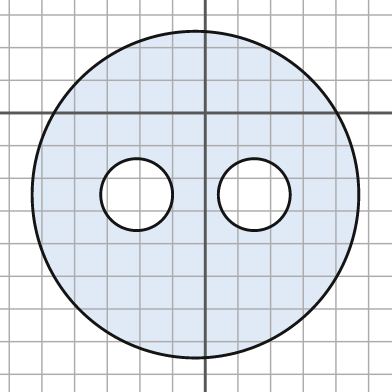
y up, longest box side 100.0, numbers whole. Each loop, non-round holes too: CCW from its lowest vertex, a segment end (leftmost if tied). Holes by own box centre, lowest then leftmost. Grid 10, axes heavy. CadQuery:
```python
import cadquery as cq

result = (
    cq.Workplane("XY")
    .moveTo(-3.0, -25.0)
    .circle(50.0)
    .moveTo(-21.0, -25.0)
    .circle(11.0)
    .moveTo(15.0, -25.0)
    .circle(11.0)
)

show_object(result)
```